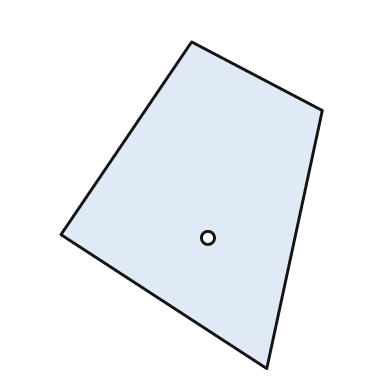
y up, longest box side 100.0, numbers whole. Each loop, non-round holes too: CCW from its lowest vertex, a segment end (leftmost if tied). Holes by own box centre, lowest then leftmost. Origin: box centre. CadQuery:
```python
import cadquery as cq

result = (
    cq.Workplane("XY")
    .moveTo(23.0, -50.0)
    .lineTo(40.0, 29.0)
    .lineTo(0.0, 50.0)
    .lineTo(-40.0, -9.0)
    .close()
    .moveTo(5.0, -10.0)
    .circle(2.0)
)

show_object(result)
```